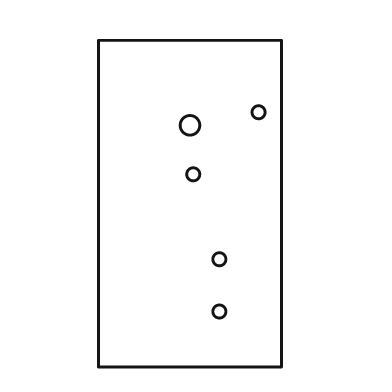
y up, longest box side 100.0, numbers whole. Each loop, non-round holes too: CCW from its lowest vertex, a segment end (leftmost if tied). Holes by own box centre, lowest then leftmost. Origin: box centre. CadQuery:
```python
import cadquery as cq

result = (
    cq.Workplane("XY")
    .moveTo(-28.0, -50.0)
    .lineTo(28.0, -50.0)
    .lineTo(28.0, 50.0)
    .lineTo(-28.0, 50.0)
    .close()
    .moveTo(9.0, -33.0)
    .circle(2.0)
    .moveTo(9.0, -17.0)
    .circle(2.0)
    .moveTo(1.0, 9.0)
    .circle(2.0)
    .moveTo(0.0, 24.0)
    .circle(3.0)
    .moveTo(21.0, 28.0)
    .circle(2.0)
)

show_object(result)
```